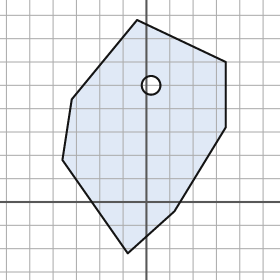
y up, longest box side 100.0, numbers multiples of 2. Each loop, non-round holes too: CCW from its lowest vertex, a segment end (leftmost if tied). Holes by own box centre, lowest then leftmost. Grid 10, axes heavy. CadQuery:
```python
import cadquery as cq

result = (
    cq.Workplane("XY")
    .moveTo(-8.0, -22.0)
    .lineTo(12.0, -4.0)
    .lineTo(34.0, 32.0)
    .lineTo(34.0, 60.0)
    .lineTo(-4.0, 78.0)
    .lineTo(-32.0, 44.0)
    .lineTo(-36.0, 18.0)
    .close()
    .moveTo(2.0, 50.0)
    .circle(4.0)
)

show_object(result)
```